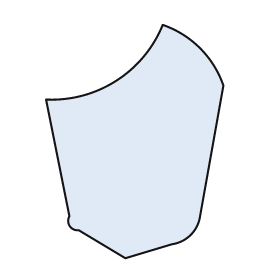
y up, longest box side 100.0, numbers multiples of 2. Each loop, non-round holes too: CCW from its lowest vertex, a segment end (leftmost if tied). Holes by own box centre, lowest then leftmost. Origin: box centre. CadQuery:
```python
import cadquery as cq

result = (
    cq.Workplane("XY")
    .moveTo(-4.0, -50.0)
    .lineTo(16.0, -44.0)
    .threePointArc((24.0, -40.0), (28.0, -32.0))
    .lineTo(38.0, 24.0)
    .threePointArc((28.0, 40.0), (12.0, 50.0))
    .threePointArc((-8.0, 26.0), (-38.0, 18.0))
    .lineTo(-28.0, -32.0)
    .threePointArc((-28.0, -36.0), (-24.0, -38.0))
    .close()
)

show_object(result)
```